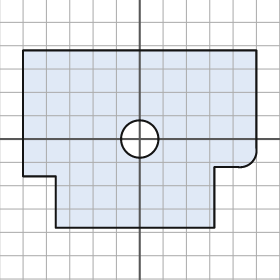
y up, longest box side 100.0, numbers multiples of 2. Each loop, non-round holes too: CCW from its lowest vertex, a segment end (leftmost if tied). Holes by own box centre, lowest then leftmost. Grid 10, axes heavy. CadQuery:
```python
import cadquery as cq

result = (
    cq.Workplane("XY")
    .moveTo(-36.0, -38.0)
    .lineTo(32.0, -38.0)
    .lineTo(32.0, -12.0)
    .lineTo(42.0, -12.0)
    .threePointArc((48.0, -10.0), (50.0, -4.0))
    .lineTo(50.0, 38.0)
    .lineTo(-50.0, 38.0)
    .lineTo(-50.0, -16.0)
    .lineTo(-36.0, -16.0)
    .close()
    .moveTo(0.0, 0.0)
    .circle(8.0)
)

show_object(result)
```